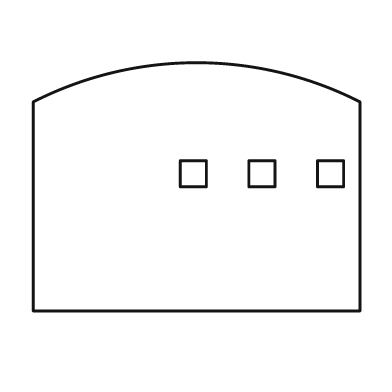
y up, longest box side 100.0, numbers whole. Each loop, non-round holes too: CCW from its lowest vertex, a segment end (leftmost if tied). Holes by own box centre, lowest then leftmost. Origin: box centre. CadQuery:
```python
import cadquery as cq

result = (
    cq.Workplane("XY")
    .moveTo(-50.0, -38.0)
    .lineTo(50.0, -38.0)
    .lineTo(50.0, 26.0)
    .threePointArc((0.0, 38.0), (-50.0, 26.0))
    .close()
    .moveTo(-5.0, 0.0)
    .lineTo(3.0, 0.0)
    .lineTo(3.0, 8.0)
    .lineTo(-5.0, 8.0)
    .close()
    .moveTo(16.0, 0.0)
    .lineTo(24.0, 0.0)
    .lineTo(24.0, 8.0)
    .lineTo(16.0, 8.0)
    .close()
    .moveTo(37.0, 0.0)
    .lineTo(45.0, 0.0)
    .lineTo(45.0, 8.0)
    .lineTo(37.0, 8.0)
    .close()
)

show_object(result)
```